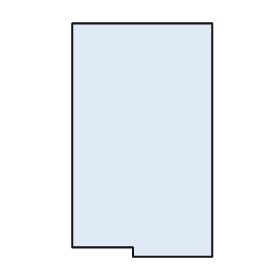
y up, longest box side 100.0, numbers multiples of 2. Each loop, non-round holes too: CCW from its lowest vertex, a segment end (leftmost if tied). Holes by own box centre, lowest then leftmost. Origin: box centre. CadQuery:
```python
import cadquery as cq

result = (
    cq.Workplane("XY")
    .moveTo(-4.0, -50.0)
    .lineTo(30.0, -50.0)
    .lineTo(30.0, 50.0)
    .lineTo(-30.0, 50.0)
    .lineTo(-30.0, -46.0)
    .lineTo(-4.0, -46.0)
    .close()
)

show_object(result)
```